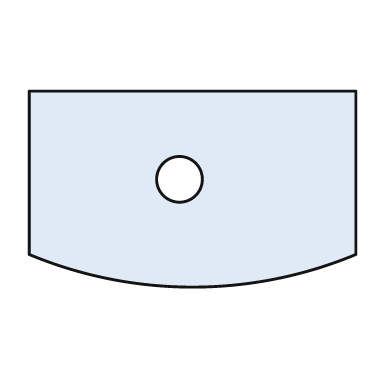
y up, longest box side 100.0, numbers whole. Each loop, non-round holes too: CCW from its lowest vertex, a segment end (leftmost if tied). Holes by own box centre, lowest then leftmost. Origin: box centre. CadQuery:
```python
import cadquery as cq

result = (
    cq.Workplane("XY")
    .moveTo(-50.0, -20.0)
    .threePointArc((0.0, -30.0), (50.0, -20.0))
    .lineTo(50.0, 30.0)
    .lineTo(-50.0, 30.0)
    .close()
    .moveTo(-4.0, 3.0)
    .circle(7.0)
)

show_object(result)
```